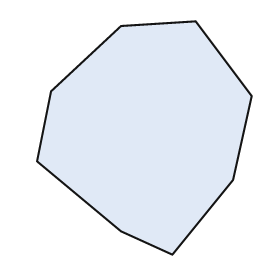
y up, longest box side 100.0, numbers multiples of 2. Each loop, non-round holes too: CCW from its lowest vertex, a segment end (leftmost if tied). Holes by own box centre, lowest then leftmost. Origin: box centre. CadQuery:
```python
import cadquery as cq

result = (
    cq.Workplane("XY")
    .moveTo(12.0, -50.0)
    .lineTo(38.0, -18.0)
    .lineTo(46.0, 18.0)
    .lineTo(22.0, 50.0)
    .lineTo(-10.0, 48.0)
    .lineTo(-40.0, 20.0)
    .lineTo(-46.0, -10.0)
    .lineTo(-10.0, -40.0)
    .close()
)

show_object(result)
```